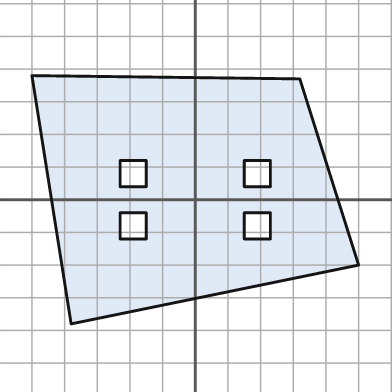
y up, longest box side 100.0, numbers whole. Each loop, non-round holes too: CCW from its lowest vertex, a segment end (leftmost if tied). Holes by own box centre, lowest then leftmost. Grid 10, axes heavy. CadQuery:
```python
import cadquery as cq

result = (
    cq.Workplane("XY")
    .moveTo(-38.0, -38.0)
    .lineTo(50.0, -20.0)
    .lineTo(32.0, 37.0)
    .lineTo(-50.0, 38.0)
    .close()
    .moveTo(-23.0, -12.0)
    .lineTo(-15.0, -12.0)
    .lineTo(-15.0, -4.0)
    .lineTo(-23.0, -4.0)
    .close()
    .moveTo(15.0, -12.0)
    .lineTo(23.0, -12.0)
    .lineTo(23.0, -4.0)
    .lineTo(15.0, -4.0)
    .close()
    .moveTo(-23.0, 4.0)
    .lineTo(-15.0, 4.0)
    .lineTo(-15.0, 12.0)
    .lineTo(-23.0, 12.0)
    .close()
    .moveTo(15.0, 4.0)
    .lineTo(23.0, 4.0)
    .lineTo(23.0, 12.0)
    .lineTo(15.0, 12.0)
    .close()
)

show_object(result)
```